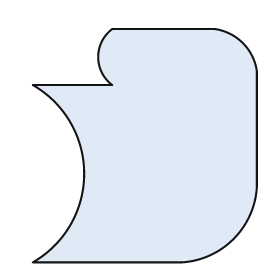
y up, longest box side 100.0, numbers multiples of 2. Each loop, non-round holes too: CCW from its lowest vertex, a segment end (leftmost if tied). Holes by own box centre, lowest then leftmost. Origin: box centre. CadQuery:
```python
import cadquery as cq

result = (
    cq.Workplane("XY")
    .moveTo(-48.0, -50.0)
    .lineTo(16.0, -50.0)
    .threePointArc((38.0, -40.0), (48.0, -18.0))
    .lineTo(48.0, 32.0)
    .threePointArc((42.0, 44.0), (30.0, 50.0))
    .lineTo(-14.0, 50.0)
    .threePointArc((-20.0, 38.0), (-14.0, 26.0))
    .lineTo(-48.0, 26.0)
    .threePointArc((-26.0, -12.0), (-48.0, -50.0))
    .close()
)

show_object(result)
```